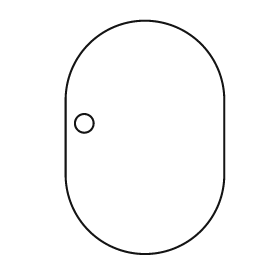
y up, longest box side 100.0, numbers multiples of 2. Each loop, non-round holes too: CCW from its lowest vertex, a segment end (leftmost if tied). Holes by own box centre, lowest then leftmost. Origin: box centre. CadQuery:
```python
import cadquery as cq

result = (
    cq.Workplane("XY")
    .moveTo(-34.0, -16.0)
    .threePointArc((0.0, -50.0), (34.0, -16.0))
    .lineTo(34.0, 16.0)
    .threePointArc((0.0, 50.0), (-34.0, 16.0))
    .close()
    .moveTo(-26.0, 6.0)
    .circle(4.0)
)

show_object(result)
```